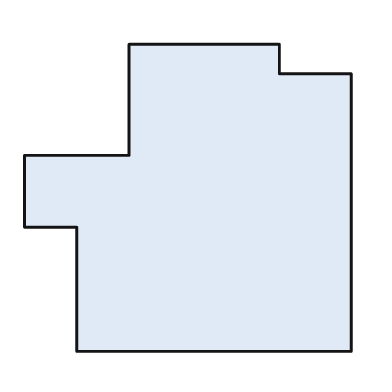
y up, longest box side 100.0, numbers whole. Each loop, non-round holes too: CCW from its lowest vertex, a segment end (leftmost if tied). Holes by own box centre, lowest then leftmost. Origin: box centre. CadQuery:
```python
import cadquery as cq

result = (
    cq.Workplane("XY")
    .moveTo(-34.0, -47.0)
    .lineTo(50.0, -47.0)
    .lineTo(50.0, 38.0)
    .lineTo(28.0, 38.0)
    .lineTo(28.0, 47.0)
    .lineTo(-18.0, 47.0)
    .lineTo(-18.0, 13.0)
    .lineTo(-50.0, 13.0)
    .lineTo(-50.0, -9.0)
    .lineTo(-34.0, -9.0)
    .close()
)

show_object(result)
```